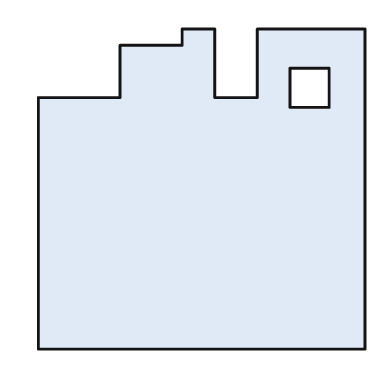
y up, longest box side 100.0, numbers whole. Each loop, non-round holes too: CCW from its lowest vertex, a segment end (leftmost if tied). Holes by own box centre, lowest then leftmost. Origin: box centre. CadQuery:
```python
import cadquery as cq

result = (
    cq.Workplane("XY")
    .moveTo(-50.0, -49.0)
    .lineTo(50.0, -49.0)
    .lineTo(50.0, 49.0)
    .lineTo(17.0, 49.0)
    .lineTo(17.0, 28.0)
    .lineTo(4.0, 28.0)
    .lineTo(4.0, 49.0)
    .lineTo(-6.0, 49.0)
    .lineTo(-6.0, 44.0)
    .lineTo(-25.0, 44.0)
    .lineTo(-25.0, 28.0)
    .lineTo(-50.0, 28.0)
    .close()
    .moveTo(27.0, 25.0)
    .lineTo(39.0, 25.0)
    .lineTo(39.0, 37.0)
    .lineTo(27.0, 37.0)
    .close()
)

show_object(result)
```